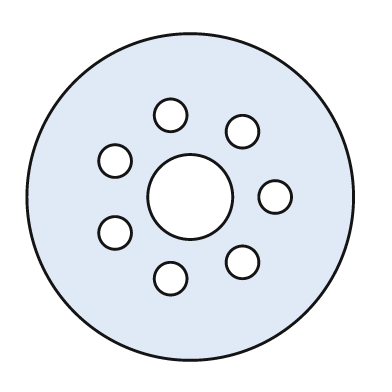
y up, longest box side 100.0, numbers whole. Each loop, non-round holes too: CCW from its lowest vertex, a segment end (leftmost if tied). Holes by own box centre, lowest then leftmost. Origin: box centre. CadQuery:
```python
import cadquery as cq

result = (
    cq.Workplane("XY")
    .moveTo(0.0, 0.0)
    .circle(50.0)
    .moveTo(-6.0, -25.0)
    .circle(5.0)
    .moveTo(16.0, -20.0)
    .circle(5.0)
    .moveTo(-23.0, -11.0)
    .circle(5.0)
    .moveTo(0.0, 0.0)
    .circle(13.0)
    .moveTo(26.0, 0.0)
    .circle(5.0)
    .moveTo(-23.0, 11.0)
    .circle(5.0)
    .moveTo(16.0, 20.0)
    .circle(5.0)
    .moveTo(-6.0, 25.0)
    .circle(5.0)
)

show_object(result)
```